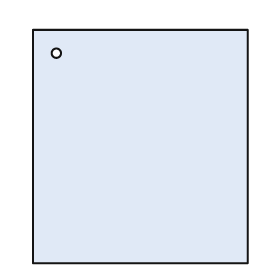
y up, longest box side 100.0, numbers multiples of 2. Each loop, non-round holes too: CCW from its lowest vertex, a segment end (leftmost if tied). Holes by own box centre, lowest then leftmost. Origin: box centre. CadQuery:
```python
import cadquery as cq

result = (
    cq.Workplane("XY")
    .moveTo(-46.0, -50.0)
    .lineTo(46.0, -50.0)
    .lineTo(46.0, 50.0)
    .lineTo(-46.0, 50.0)
    .close()
    .moveTo(-36.0, 40.0)
    .circle(2.0)
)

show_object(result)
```